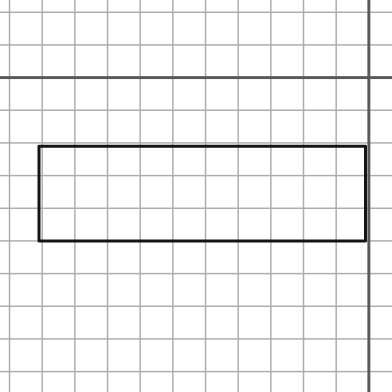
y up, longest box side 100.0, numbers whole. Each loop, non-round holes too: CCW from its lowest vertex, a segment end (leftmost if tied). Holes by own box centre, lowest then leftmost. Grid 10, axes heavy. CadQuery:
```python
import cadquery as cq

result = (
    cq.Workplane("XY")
    .moveTo(-101.0, -50.0)
    .lineTo(-1.0, -50.0)
    .lineTo(-1.0, -21.0)
    .lineTo(-101.0, -21.0)
    .close()
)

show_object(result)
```